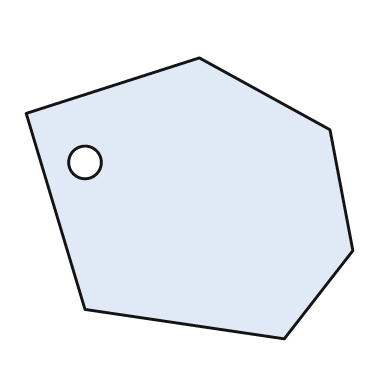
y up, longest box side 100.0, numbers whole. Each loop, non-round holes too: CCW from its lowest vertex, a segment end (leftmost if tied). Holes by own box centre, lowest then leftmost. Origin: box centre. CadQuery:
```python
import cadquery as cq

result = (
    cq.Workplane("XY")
    .moveTo(29.0, -43.0)
    .lineTo(50.0, -16.0)
    .lineTo(43.0, 21.0)
    .lineTo(3.0, 43.0)
    .lineTo(-50.0, 26.0)
    .lineTo(-32.0, -34.0)
    .close()
    .moveTo(-32.0, 11.0)
    .circle(5.0)
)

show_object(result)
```